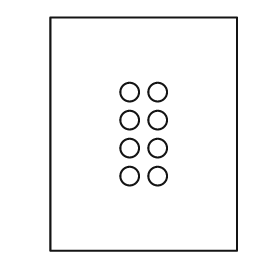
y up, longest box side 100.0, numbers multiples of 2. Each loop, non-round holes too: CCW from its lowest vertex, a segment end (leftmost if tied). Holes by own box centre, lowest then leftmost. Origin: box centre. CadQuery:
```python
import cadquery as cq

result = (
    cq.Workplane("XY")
    .moveTo(-40.0, -50.0)
    .lineTo(40.0, -50.0)
    .lineTo(40.0, 50.0)
    .lineTo(-40.0, 50.0)
    .close()
    .moveTo(-6.0, -18.0)
    .circle(4.0)
    .moveTo(6.0, -18.0)
    .circle(4.0)
    .moveTo(-6.0, -6.0)
    .circle(4.0)
    .moveTo(6.0, -6.0)
    .circle(4.0)
    .moveTo(-6.0, 6.0)
    .circle(4.0)
    .moveTo(6.0, 6.0)
    .circle(4.0)
    .moveTo(-6.0, 18.0)
    .circle(4.0)
    .moveTo(6.0, 18.0)
    .circle(4.0)
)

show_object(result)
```